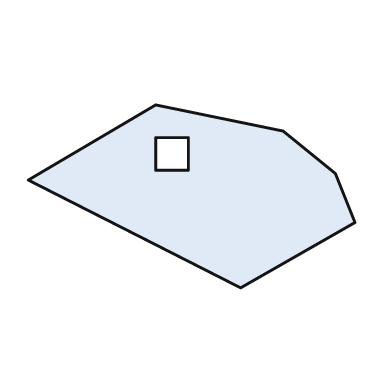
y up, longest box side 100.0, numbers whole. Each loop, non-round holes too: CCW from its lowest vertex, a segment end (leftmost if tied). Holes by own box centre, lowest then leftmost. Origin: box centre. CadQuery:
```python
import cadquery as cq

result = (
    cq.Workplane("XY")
    .moveTo(15.0, -28.0)
    .lineTo(50.0, -8.0)
    .lineTo(44.0, 7.0)
    .lineTo(28.0, 20.0)
    .lineTo(-11.0, 28.0)
    .lineTo(-50.0, 5.0)
    .close()
    .moveTo(-11.0, 8.0)
    .lineTo(-1.0, 8.0)
    .lineTo(-1.0, 18.0)
    .lineTo(-11.0, 18.0)
    .close()
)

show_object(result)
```